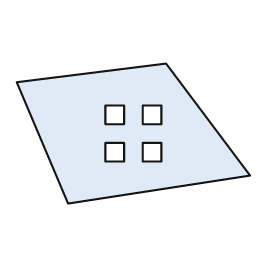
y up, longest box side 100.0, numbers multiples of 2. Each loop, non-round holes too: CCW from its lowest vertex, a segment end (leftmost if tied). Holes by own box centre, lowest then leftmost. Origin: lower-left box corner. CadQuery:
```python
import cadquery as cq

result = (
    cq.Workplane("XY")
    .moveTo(22.0, 0.0)
    .lineTo(100.0, 12.0)
    .lineTo(64.0, 60.0)
    .lineTo(0.0, 52.0)
    .close()
    .moveTo(38.0, 18.0)
    .lineTo(46.0, 18.0)
    .lineTo(46.0, 26.0)
    .lineTo(38.0, 26.0)
    .close()
    .moveTo(54.0, 18.0)
    .lineTo(62.0, 18.0)
    .lineTo(62.0, 26.0)
    .lineTo(54.0, 26.0)
    .close()
    .moveTo(38.0, 34.0)
    .lineTo(46.0, 34.0)
    .lineTo(46.0, 42.0)
    .lineTo(38.0, 42.0)
    .close()
    .moveTo(54.0, 34.0)
    .lineTo(62.0, 34.0)
    .lineTo(62.0, 42.0)
    .lineTo(54.0, 42.0)
    .close()
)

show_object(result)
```